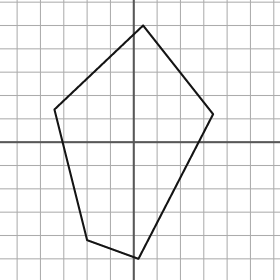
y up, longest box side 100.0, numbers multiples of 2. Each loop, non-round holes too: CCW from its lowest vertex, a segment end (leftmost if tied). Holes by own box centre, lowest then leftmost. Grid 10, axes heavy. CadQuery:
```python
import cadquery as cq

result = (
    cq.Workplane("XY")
    .moveTo(2.0, -50.0)
    .lineTo(34.0, 12.0)
    .lineTo(4.0, 50.0)
    .lineTo(-34.0, 14.0)
    .lineTo(-20.0, -42.0)
    .close()
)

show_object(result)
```